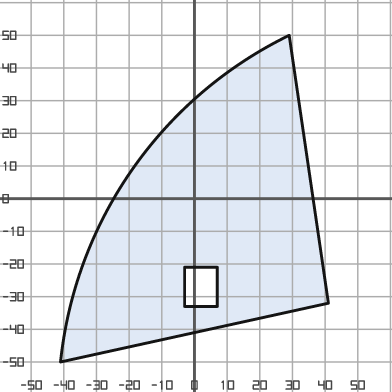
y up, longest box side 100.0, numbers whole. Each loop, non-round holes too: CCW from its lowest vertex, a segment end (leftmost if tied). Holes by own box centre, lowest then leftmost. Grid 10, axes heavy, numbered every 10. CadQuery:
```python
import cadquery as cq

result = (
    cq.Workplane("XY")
    .moveTo(-41.0, -50.0)
    .lineTo(41.0, -32.0)
    .lineTo(29.0, 50.0)
    .threePointArc((-19.0, 9.0), (-41.0, -50.0))
    .close()
    .moveTo(-3.0, -33.0)
    .lineTo(7.0, -33.0)
    .lineTo(7.0, -21.0)
    .lineTo(-3.0, -21.0)
    .close()
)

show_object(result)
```